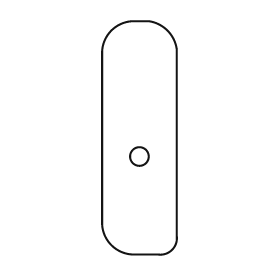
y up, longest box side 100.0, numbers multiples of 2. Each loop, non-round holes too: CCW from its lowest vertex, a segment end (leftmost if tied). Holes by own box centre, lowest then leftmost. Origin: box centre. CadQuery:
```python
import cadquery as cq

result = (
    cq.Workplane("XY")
    .moveTo(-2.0, -50.0)
    .lineTo(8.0, -50.0)
    .threePointArc((14.0, -48.0), (16.0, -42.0))
    .lineTo(16.0, 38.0)
    .threePointArc((12.0, 46.0), (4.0, 50.0))
    .lineTo(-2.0, 50.0)
    .threePointArc((-12.0, 46.0), (-16.0, 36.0))
    .lineTo(-16.0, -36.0)
    .threePointArc((-12.0, -46.0), (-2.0, -50.0))
    .close()
    .moveTo(0.0, -8.0)
    .circle(4.0)
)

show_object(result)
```